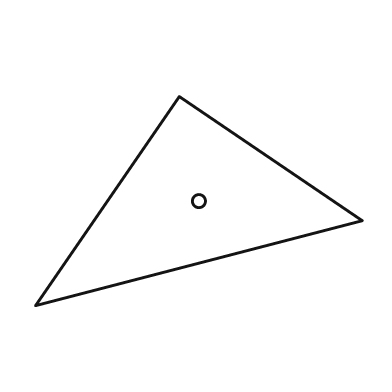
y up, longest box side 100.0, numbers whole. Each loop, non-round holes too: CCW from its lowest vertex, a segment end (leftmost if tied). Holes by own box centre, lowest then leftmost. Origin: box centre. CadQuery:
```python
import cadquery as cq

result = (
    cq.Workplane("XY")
    .moveTo(-50.0, -32.0)
    .lineTo(50.0, -6.0)
    .lineTo(-6.0, 32.0)
    .close()
    .moveTo(0.0, 0.0)
    .circle(2.0)
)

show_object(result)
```